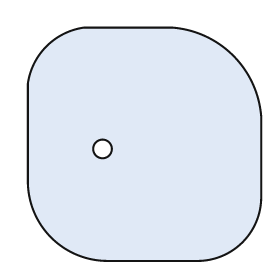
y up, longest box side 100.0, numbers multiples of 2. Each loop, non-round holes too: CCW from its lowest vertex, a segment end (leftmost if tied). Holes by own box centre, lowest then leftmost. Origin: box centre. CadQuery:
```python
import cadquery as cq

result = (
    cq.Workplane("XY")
    .moveTo(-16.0, -50.0)
    .lineTo(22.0, -50.0)
    .threePointArc((42.0, -42.0), (50.0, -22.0))
    .lineTo(50.0, 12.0)
    .threePointArc((38.0, 38.0), (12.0, 50.0))
    .lineTo(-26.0, 50.0)
    .threePointArc((-42.0, 42.0), (-50.0, 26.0))
    .lineTo(-50.0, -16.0)
    .threePointArc((-40.0, -40.0), (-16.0, -50.0))
    .close()
    .moveTo(-18.0, -2.0)
    .circle(4.0)
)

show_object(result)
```